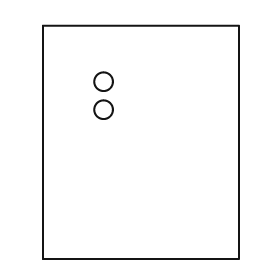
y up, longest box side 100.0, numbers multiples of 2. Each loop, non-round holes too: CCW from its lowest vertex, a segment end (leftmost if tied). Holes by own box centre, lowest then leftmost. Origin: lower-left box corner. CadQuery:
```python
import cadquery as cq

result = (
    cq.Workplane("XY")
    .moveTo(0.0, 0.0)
    .lineTo(84.0, 0.0)
    .lineTo(84.0, 100.0)
    .lineTo(0.0, 100.0)
    .close()
    .moveTo(26.0, 64.0)
    .circle(4.0)
    .moveTo(26.0, 76.0)
    .circle(4.0)
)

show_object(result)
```